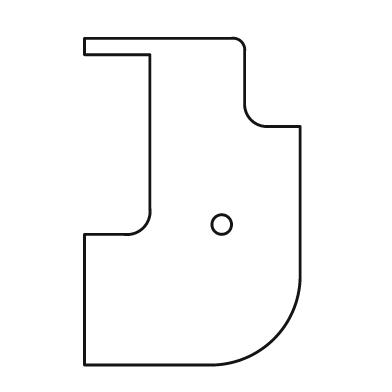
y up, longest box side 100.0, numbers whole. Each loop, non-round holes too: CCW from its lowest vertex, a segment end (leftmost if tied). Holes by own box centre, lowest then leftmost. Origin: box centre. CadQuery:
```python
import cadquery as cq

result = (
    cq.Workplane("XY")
    .moveTo(-33.0, -50.0)
    .lineTo(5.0, -50.0)
    .threePointArc((25.0, -42.0), (33.0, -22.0))
    .lineTo(33.0, 23.0)
    .lineTo(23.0, 23.0)
    .threePointArc((18.0, 25.0), (16.0, 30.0))
    .lineTo(16.0, 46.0)
    .threePointArc((15.0, 49.0), (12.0, 50.0))
    .lineTo(-33.0, 50.0)
    .lineTo(-33.0, 45.0)
    .lineTo(-13.0, 45.0)
    .lineTo(-13.0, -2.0)
    .threePointArc((-15.0, -8.0), (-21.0, -10.0))
    .lineTo(-33.0, -10.0)
    .close()
    .moveTo(9.0, -7.0)
    .circle(3.0)
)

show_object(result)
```